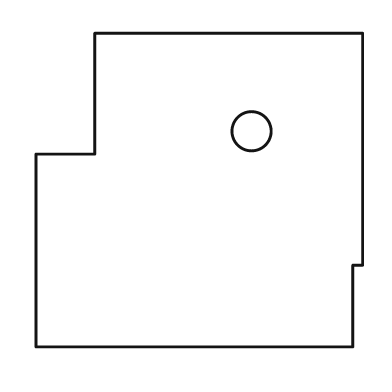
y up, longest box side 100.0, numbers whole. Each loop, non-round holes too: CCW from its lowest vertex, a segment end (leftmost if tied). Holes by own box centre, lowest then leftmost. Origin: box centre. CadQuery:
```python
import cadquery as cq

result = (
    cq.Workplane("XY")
    .moveTo(-50.0, -48.0)
    .lineTo(47.0, -48.0)
    .lineTo(47.0, -23.0)
    .lineTo(50.0, -23.0)
    .lineTo(50.0, 48.0)
    .lineTo(-32.0, 48.0)
    .lineTo(-32.0, 11.0)
    .lineTo(-50.0, 11.0)
    .close()
    .moveTo(16.0, 18.0)
    .circle(6.0)
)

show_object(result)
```